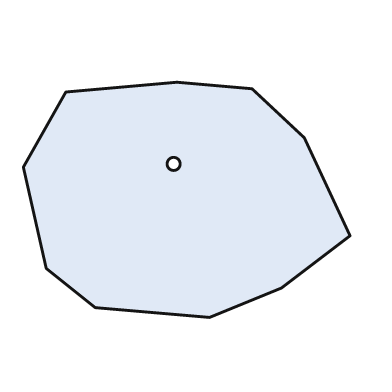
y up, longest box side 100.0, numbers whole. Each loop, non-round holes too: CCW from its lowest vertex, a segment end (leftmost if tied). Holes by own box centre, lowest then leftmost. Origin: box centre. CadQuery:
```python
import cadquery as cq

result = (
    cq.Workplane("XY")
    .moveTo(7.0, -36.0)
    .lineTo(29.0, -27.0)
    .lineTo(50.0, -11.0)
    .lineTo(36.0, 19.0)
    .lineTo(20.0, 34.0)
    .lineTo(-3.0, 36.0)
    .lineTo(-37.0, 33.0)
    .lineTo(-50.0, 10.0)
    .lineTo(-43.0, -21.0)
    .lineTo(-28.0, -33.0)
    .close()
    .moveTo(-4.0, 11.0)
    .circle(2.0)
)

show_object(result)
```